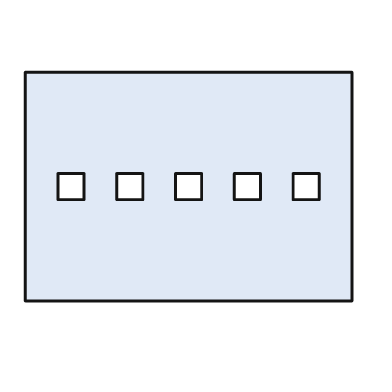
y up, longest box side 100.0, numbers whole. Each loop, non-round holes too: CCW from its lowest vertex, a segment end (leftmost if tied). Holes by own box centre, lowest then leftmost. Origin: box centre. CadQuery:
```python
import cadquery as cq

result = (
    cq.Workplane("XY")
    .moveTo(-50.0, -35.0)
    .lineTo(50.0, -35.0)
    .lineTo(50.0, 35.0)
    .lineTo(-50.0, 35.0)
    .close()
    .moveTo(-40.0, -4.0)
    .lineTo(-32.0, -4.0)
    .lineTo(-32.0, 4.0)
    .lineTo(-40.0, 4.0)
    .close()
    .moveTo(-22.0, -4.0)
    .lineTo(-14.0, -4.0)
    .lineTo(-14.0, 4.0)
    .lineTo(-22.0, 4.0)
    .close()
    .moveTo(-4.0, -4.0)
    .lineTo(4.0, -4.0)
    .lineTo(4.0, 4.0)
    .lineTo(-4.0, 4.0)
    .close()
    .moveTo(14.0, -4.0)
    .lineTo(22.0, -4.0)
    .lineTo(22.0, 4.0)
    .lineTo(14.0, 4.0)
    .close()
    .moveTo(32.0, -4.0)
    .lineTo(40.0, -4.0)
    .lineTo(40.0, 4.0)
    .lineTo(32.0, 4.0)
    .close()
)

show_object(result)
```